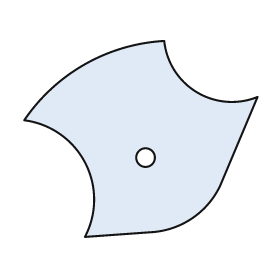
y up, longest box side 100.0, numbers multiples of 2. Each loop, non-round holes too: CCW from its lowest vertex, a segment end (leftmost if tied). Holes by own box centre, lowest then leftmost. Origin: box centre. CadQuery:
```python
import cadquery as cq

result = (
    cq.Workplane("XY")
    .moveTo(-24.0, -42.0)
    .lineTo(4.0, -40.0)
    .threePointArc((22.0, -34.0), (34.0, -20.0))
    .lineTo(50.0, 18.0)
    .threePointArc((24.0, 20.0), (10.0, 42.0))
    .threePointArc((-24.0, 32.0), (-50.0, 8.0))
    .threePointArc((-24.0, -10.0), (-24.0, -42.0))
    .close()
    .moveTo(2.0, -8.0)
    .circle(4.0)
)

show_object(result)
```